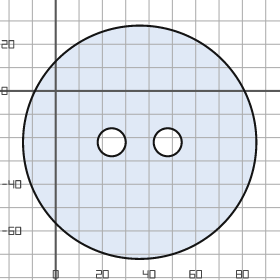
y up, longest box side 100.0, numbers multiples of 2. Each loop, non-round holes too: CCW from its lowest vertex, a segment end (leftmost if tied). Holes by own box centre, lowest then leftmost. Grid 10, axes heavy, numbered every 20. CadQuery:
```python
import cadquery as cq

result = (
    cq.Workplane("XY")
    .moveTo(36.0, -22.0)
    .circle(50.0)
    .moveTo(24.0, -22.0)
    .circle(6.0)
    .moveTo(48.0, -22.0)
    .circle(6.0)
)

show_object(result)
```